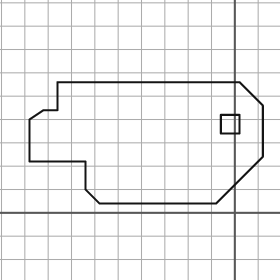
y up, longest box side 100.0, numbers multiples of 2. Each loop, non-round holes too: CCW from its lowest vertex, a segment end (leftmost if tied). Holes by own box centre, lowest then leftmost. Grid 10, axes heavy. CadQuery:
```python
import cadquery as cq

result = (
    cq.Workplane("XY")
    .moveTo(-58.0, 4.0)
    .lineTo(-8.0, 4.0)
    .lineTo(12.0, 24.0)
    .lineTo(12.0, 46.0)
    .lineTo(2.0, 56.0)
    .lineTo(-76.0, 56.0)
    .lineTo(-76.0, 44.0)
    .lineTo(-82.0, 44.0)
    .lineTo(-88.0, 40.0)
    .lineTo(-88.0, 22.0)
    .lineTo(-64.0, 22.0)
    .lineTo(-64.0, 10.0)
    .close()
    .moveTo(-6.0, 34.0)
    .lineTo(2.0, 34.0)
    .lineTo(2.0, 42.0)
    .lineTo(-6.0, 42.0)
    .close()
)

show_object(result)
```